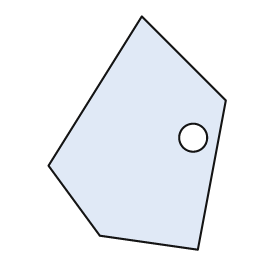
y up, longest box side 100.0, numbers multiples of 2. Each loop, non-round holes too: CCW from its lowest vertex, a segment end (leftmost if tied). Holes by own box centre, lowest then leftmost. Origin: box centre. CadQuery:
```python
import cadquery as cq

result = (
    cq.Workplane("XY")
    .moveTo(26.0, -50.0)
    .lineTo(38.0, 14.0)
    .lineTo(2.0, 50.0)
    .lineTo(-38.0, -14.0)
    .lineTo(-16.0, -44.0)
    .close()
    .moveTo(24.0, -2.0)
    .circle(6.0)
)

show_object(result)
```